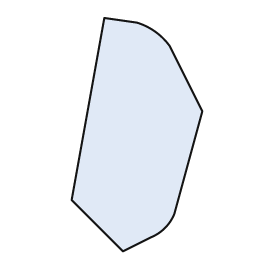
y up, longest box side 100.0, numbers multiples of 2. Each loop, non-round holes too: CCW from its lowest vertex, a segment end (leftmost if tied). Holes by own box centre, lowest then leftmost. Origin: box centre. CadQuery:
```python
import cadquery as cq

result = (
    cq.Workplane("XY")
    .moveTo(-6.0, -50.0)
    .lineTo(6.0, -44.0)
    .threePointArc((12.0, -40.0), (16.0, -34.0))
    .lineTo(28.0, 10.0)
    .lineTo(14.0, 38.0)
    .threePointArc((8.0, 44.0), (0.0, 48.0))
    .lineTo(-14.0, 50.0)
    .lineTo(-28.0, -28.0)
    .close()
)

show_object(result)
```